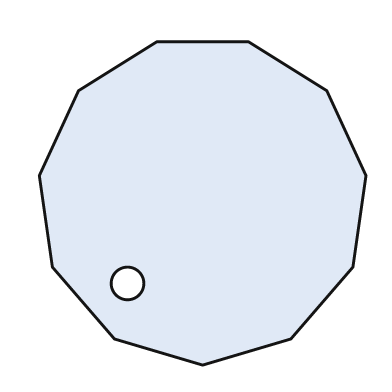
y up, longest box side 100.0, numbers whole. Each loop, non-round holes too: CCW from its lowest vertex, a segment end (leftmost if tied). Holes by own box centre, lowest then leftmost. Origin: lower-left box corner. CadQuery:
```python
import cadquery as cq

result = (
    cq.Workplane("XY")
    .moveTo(50.0, 0.0)
    .lineTo(77.0, 8.0)
    .lineTo(96.0, 30.0)
    .lineTo(100.0, 58.0)
    .lineTo(88.0, 84.0)
    .lineTo(64.0, 99.0)
    .lineTo(36.0, 99.0)
    .lineTo(12.0, 84.0)
    .lineTo(0.0, 58.0)
    .lineTo(4.0, 30.0)
    .lineTo(23.0, 8.0)
    .close()
    .moveTo(27.0, 25.0)
    .circle(5.0)
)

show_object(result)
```